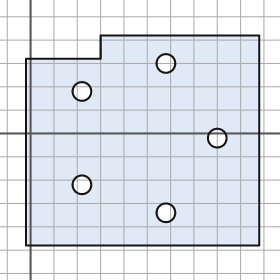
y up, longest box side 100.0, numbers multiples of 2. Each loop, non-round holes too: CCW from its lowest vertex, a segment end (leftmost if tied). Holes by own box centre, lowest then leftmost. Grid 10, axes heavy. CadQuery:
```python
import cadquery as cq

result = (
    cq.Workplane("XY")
    .moveTo(-2.0, -48.0)
    .lineTo(98.0, -48.0)
    .lineTo(98.0, 42.0)
    .lineTo(30.0, 42.0)
    .lineTo(30.0, 32.0)
    .lineTo(-2.0, 32.0)
    .close()
    .moveTo(58.0, -34.0)
    .circle(4.0)
    .moveTo(22.0, -22.0)
    .circle(4.0)
    .moveTo(80.0, -2.0)
    .circle(4.0)
    .moveTo(22.0, 18.0)
    .circle(4.0)
    .moveTo(58.0, 30.0)
    .circle(4.0)
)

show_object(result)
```